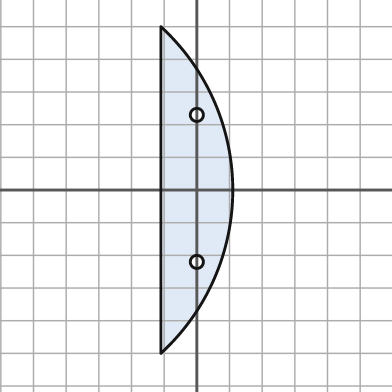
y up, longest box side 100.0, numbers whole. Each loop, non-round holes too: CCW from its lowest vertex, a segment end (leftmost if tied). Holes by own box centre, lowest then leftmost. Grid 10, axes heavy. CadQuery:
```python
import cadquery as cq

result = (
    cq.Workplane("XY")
    .moveTo(-11.0, -50.0)
    .threePointArc((11.0, 0.0), (-11.0, 50.0))
    .close()
    .moveTo(0.0, -22.0)
    .circle(2.0)
    .moveTo(0.0, 23.0)
    .circle(2.0)
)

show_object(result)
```